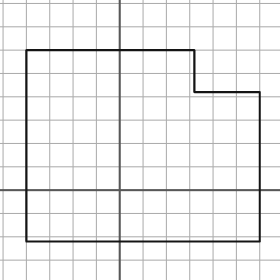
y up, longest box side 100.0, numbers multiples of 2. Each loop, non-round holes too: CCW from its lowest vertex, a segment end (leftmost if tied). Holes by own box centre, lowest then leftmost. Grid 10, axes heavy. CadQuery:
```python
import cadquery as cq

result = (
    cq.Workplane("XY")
    .moveTo(-40.0, -22.0)
    .lineTo(60.0, -22.0)
    .lineTo(60.0, 42.0)
    .lineTo(32.0, 42.0)
    .lineTo(32.0, 60.0)
    .lineTo(-40.0, 60.0)
    .close()
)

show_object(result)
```